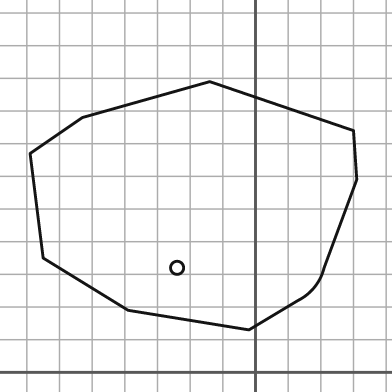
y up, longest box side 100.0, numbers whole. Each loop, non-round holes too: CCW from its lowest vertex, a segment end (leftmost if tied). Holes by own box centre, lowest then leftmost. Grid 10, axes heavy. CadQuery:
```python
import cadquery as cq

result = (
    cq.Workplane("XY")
    .moveTo(-2.0, 13.0)
    .lineTo(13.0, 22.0)
    .threePointArc((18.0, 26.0), (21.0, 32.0))
    .lineTo(31.0, 59.0)
    .lineTo(30.0, 74.0)
    .lineTo(-14.0, 89.0)
    .lineTo(-53.0, 78.0)
    .lineTo(-69.0, 67.0)
    .lineTo(-65.0, 35.0)
    .lineTo(-39.0, 19.0)
    .close()
    .moveTo(-24.0, 32.0)
    .circle(2.0)
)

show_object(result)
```